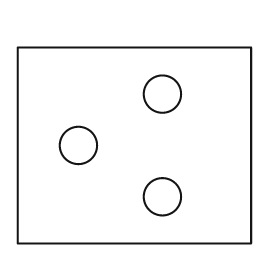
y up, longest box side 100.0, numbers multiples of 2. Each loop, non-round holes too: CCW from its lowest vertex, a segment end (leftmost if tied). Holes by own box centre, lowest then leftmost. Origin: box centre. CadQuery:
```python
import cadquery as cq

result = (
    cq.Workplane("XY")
    .moveTo(-50.0, -42.0)
    .lineTo(50.0, -42.0)
    .lineTo(50.0, 42.0)
    .lineTo(-50.0, 42.0)
    .close()
    .moveTo(12.0, -22.0)
    .circle(8.0)
    .moveTo(-24.0, 0.0)
    .circle(8.0)
    .moveTo(12.0, 22.0)
    .circle(8.0)
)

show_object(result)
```